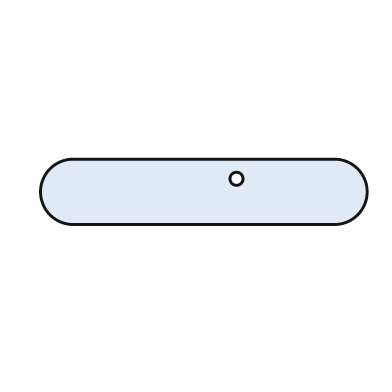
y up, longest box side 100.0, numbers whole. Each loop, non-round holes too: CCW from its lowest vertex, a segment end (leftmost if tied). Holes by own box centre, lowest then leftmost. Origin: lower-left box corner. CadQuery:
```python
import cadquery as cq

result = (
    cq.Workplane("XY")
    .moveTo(10.0, 0.0)
    .lineTo(90.0, 0.0)
    .threePointArc((100.0, 10.0), (90.0, 20.0))
    .lineTo(10.0, 20.0)
    .threePointArc((0.0, 10.0), (10.0, 0.0))
    .close()
    .moveTo(60.0, 14.0)
    .circle(2.0)
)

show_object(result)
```